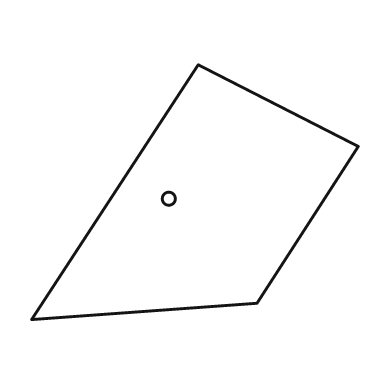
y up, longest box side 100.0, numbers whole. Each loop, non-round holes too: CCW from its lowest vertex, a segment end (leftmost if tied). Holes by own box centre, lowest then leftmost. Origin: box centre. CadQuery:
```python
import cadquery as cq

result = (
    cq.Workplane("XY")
    .moveTo(-50.0, -39.0)
    .lineTo(19.0, -34.0)
    .lineTo(50.0, 14.0)
    .lineTo(1.0, 39.0)
    .close()
    .moveTo(-8.0, -2.0)
    .circle(2.0)
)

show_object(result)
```